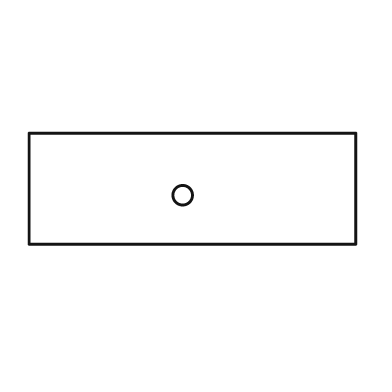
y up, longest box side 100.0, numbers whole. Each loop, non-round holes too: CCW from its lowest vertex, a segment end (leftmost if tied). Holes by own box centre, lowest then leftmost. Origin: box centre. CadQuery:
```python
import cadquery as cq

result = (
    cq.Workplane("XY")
    .moveTo(-50.0, -17.0)
    .lineTo(50.0, -17.0)
    .lineTo(50.0, 17.0)
    .lineTo(-50.0, 17.0)
    .close()
    .moveTo(-3.0, -2.0)
    .circle(3.0)
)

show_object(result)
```